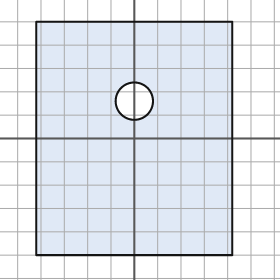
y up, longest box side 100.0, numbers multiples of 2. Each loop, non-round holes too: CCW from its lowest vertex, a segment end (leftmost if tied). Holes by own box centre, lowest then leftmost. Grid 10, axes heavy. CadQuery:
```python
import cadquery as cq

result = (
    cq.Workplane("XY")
    .moveTo(-42.0, -50.0)
    .lineTo(42.0, -50.0)
    .lineTo(42.0, 50.0)
    .lineTo(-42.0, 50.0)
    .close()
    .moveTo(0.0, 16.0)
    .circle(8.0)
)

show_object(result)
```